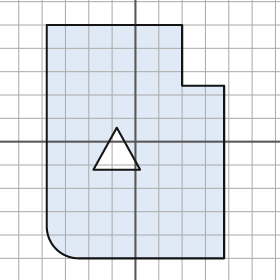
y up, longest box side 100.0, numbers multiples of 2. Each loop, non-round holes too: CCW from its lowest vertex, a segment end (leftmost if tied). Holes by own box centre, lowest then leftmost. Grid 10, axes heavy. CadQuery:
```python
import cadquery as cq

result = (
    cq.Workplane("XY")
    .moveTo(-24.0, -50.0)
    .lineTo(38.0, -50.0)
    .lineTo(38.0, 24.0)
    .lineTo(20.0, 24.0)
    .lineTo(20.0, 50.0)
    .lineTo(-38.0, 50.0)
    .lineTo(-38.0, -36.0)
    .threePointArc((-34.0, -46.0), (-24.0, -50.0))
    .close()
    .moveTo(-18.0, -12.0)
    .lineTo(2.0, -12.0)
    .lineTo(-8.0, 6.0)
    .close()
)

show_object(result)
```